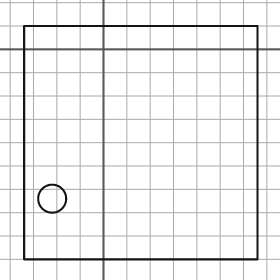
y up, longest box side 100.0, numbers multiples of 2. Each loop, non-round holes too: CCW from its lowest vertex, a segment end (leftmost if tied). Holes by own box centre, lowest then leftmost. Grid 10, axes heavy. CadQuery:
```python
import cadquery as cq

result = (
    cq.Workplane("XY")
    .moveTo(-34.0, -90.0)
    .lineTo(66.0, -90.0)
    .lineTo(66.0, 10.0)
    .lineTo(-34.0, 10.0)
    .close()
    .moveTo(-22.0, -64.0)
    .circle(6.0)
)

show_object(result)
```